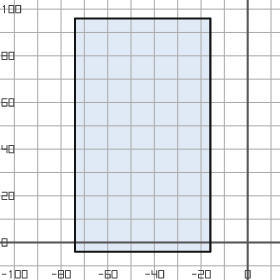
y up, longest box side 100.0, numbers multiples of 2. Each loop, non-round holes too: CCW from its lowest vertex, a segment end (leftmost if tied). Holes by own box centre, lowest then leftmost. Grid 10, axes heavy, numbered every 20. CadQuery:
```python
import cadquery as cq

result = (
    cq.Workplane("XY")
    .moveTo(-74.0, -4.0)
    .lineTo(-16.0, -4.0)
    .lineTo(-16.0, 96.0)
    .lineTo(-74.0, 96.0)
    .close()
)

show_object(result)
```